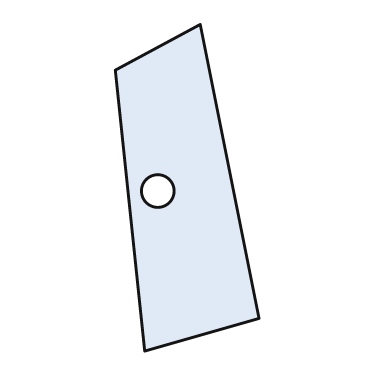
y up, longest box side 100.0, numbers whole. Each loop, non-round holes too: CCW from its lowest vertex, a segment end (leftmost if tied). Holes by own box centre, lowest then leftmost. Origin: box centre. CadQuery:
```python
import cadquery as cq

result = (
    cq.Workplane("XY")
    .moveTo(-13.0, -50.0)
    .lineTo(22.0, -40.0)
    .lineTo(4.0, 50.0)
    .lineTo(-22.0, 36.0)
    .close()
    .moveTo(-9.0, -1.0)
    .circle(5.0)
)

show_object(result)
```